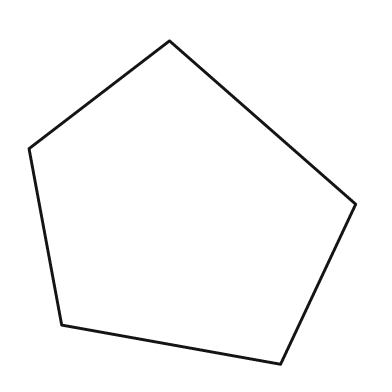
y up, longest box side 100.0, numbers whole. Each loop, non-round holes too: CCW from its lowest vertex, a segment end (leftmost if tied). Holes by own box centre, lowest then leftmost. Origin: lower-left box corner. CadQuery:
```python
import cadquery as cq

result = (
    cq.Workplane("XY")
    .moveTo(77.0, 0.0)
    .lineTo(100.0, 49.0)
    .lineTo(43.0, 99.0)
    .lineTo(0.0, 66.0)
    .lineTo(10.0, 12.0)
    .close()
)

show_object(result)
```